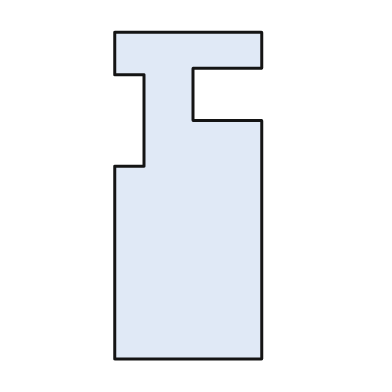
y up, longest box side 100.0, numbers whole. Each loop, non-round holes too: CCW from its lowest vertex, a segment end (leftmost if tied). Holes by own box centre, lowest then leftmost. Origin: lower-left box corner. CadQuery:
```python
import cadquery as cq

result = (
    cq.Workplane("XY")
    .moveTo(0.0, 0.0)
    .lineTo(45.0, 0.0)
    .lineTo(45.0, 73.0)
    .lineTo(24.0, 73.0)
    .lineTo(24.0, 89.0)
    .lineTo(45.0, 89.0)
    .lineTo(45.0, 100.0)
    .lineTo(0.0, 100.0)
    .lineTo(0.0, 87.0)
    .lineTo(9.0, 87.0)
    .lineTo(9.0, 59.0)
    .lineTo(0.0, 59.0)
    .close()
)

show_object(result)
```